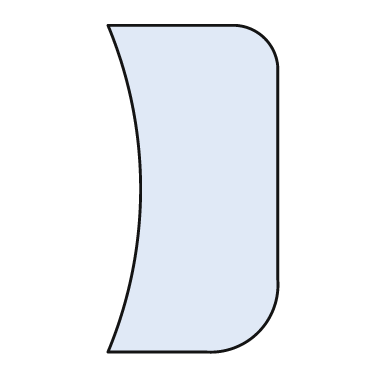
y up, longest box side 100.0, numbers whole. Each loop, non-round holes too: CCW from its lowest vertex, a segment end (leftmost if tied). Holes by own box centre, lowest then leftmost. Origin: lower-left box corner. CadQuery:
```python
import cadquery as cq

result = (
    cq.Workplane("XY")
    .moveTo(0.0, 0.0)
    .lineTo(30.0, 0.0)
    .threePointArc((46.0, 6.0), (52.0, 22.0))
    .lineTo(52.0, 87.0)
    .threePointArc((48.0, 96.0), (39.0, 100.0))
    .lineTo(0.0, 100.0)
    .threePointArc((10.0, 50.0), (0.0, 0.0))
    .close()
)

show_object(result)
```